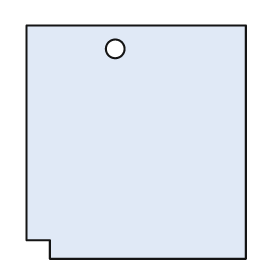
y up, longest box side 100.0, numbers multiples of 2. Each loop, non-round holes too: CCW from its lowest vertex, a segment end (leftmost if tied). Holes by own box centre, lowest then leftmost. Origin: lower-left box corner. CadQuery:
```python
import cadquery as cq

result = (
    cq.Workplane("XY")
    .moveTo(10.0, 0.0)
    .lineTo(94.0, 0.0)
    .lineTo(94.0, 100.0)
    .lineTo(0.0, 100.0)
    .lineTo(0.0, 8.0)
    .lineTo(10.0, 8.0)
    .close()
    .moveTo(38.0, 90.0)
    .circle(4.0)
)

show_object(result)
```